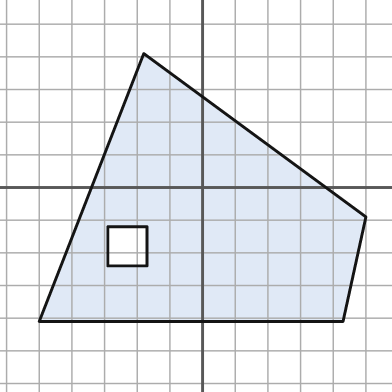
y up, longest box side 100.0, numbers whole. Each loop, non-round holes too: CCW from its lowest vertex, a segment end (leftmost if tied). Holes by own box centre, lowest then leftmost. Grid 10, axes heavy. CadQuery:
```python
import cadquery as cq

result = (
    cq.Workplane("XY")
    .moveTo(-50.0, -41.0)
    .lineTo(43.0, -41.0)
    .lineTo(50.0, -9.0)
    .lineTo(-18.0, 41.0)
    .close()
    .moveTo(-29.0, -24.0)
    .lineTo(-17.0, -24.0)
    .lineTo(-17.0, -12.0)
    .lineTo(-29.0, -12.0)
    .close()
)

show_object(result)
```